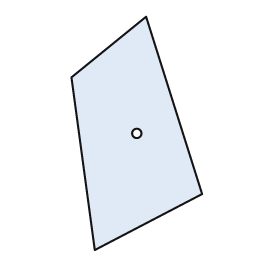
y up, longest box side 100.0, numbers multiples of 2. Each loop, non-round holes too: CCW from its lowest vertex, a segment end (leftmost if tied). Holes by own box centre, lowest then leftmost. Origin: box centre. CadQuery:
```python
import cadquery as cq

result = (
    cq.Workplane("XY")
    .moveTo(-18.0, -50.0)
    .lineTo(28.0, -26.0)
    .lineTo(4.0, 50.0)
    .lineTo(-28.0, 24.0)
    .close()
    .moveTo(0.0, 0.0)
    .circle(2.0)
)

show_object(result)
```